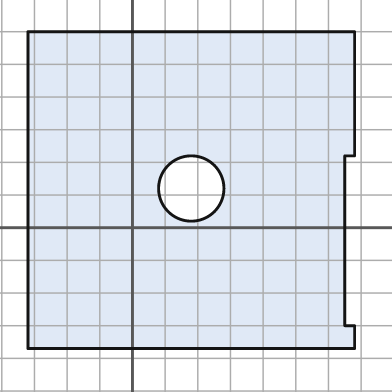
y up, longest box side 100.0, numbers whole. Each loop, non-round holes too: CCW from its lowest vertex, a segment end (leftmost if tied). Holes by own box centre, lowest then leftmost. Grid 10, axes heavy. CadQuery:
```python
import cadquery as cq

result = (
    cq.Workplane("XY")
    .moveTo(-32.0, -37.0)
    .lineTo(68.0, -37.0)
    .lineTo(68.0, -30.0)
    .lineTo(65.0, -30.0)
    .lineTo(65.0, 22.0)
    .lineTo(68.0, 22.0)
    .lineTo(68.0, 60.0)
    .lineTo(-32.0, 60.0)
    .close()
    .moveTo(18.0, 12.0)
    .circle(10.0)
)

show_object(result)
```